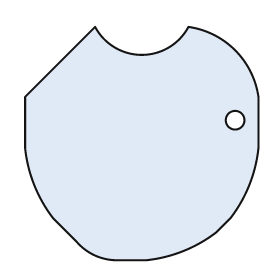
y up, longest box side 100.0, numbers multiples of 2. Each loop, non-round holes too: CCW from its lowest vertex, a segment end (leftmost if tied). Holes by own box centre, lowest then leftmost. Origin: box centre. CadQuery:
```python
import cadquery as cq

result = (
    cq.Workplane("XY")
    .moveTo(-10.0, -50.0)
    .lineTo(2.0, -50.0)
    .threePointArc((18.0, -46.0), (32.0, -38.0))
    .lineTo(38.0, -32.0)
    .threePointArc((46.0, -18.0), (50.0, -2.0))
    .lineTo(50.0, 20.0)
    .threePointArc((40.0, 40.0), (20.0, 50.0))
    .threePointArc((0.0, 38.0), (-20.0, 50.0))
    .lineTo(-50.0, 20.0)
    .lineTo(-50.0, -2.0)
    .threePointArc((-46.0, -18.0), (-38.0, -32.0))
    .lineTo(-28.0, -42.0)
    .threePointArc((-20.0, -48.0), (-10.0, -50.0))
    .close()
    .moveTo(40.0, 10.0)
    .circle(4.0)
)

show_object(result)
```